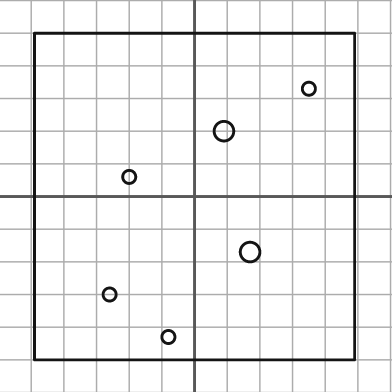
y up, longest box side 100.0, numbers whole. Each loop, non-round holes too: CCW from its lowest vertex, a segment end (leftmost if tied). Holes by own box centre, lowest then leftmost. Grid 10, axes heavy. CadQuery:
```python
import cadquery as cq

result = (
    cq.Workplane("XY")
    .moveTo(-49.0, -50.0)
    .lineTo(49.0, -50.0)
    .lineTo(49.0, 50.0)
    .lineTo(-49.0, 50.0)
    .close()
    .moveTo(-8.0, -43.0)
    .circle(2.0)
    .moveTo(-26.0, -30.0)
    .circle(2.0)
    .moveTo(17.0, -17.0)
    .circle(3.0)
    .moveTo(-20.0, 6.0)
    .circle(2.0)
    .moveTo(9.0, 20.0)
    .circle(3.0)
    .moveTo(35.0, 33.0)
    .circle(2.0)
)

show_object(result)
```